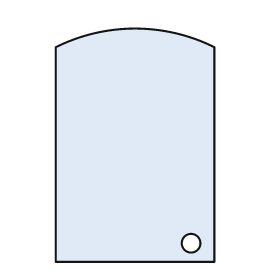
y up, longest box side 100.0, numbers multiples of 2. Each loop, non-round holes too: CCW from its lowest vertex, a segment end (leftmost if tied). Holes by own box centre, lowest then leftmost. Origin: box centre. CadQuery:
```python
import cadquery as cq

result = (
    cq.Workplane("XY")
    .moveTo(-34.0, -50.0)
    .lineTo(34.0, -50.0)
    .lineTo(34.0, 42.0)
    .threePointArc((0.0, 50.0), (-34.0, 42.0))
    .close()
    .moveTo(24.0, -42.0)
    .circle(4.0)
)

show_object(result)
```